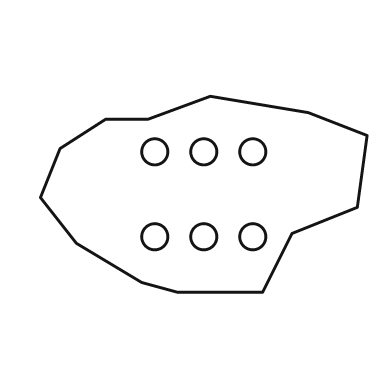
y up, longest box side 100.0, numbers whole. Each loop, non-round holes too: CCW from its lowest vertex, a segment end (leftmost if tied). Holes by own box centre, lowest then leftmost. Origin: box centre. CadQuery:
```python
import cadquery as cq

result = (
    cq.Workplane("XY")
    .moveTo(-8.0, -30.0)
    .lineTo(18.0, -30.0)
    .lineTo(27.0, -12.0)
    .lineTo(47.0, -4.0)
    .lineTo(50.0, 18.0)
    .lineTo(32.0, 25.0)
    .lineTo(2.0, 30.0)
    .lineTo(-17.0, 23.0)
    .lineTo(-30.0, 23.0)
    .lineTo(-44.0, 14.0)
    .lineTo(-50.0, -1.0)
    .lineTo(-39.0, -15.0)
    .lineTo(-19.0, -27.0)
    .close()
    .moveTo(-15.0, -13.0)
    .circle(4.0)
    .moveTo(0.0, -13.0)
    .circle(4.0)
    .moveTo(15.0, -13.0)
    .circle(4.0)
    .moveTo(-15.0, 13.0)
    .circle(4.0)
    .moveTo(0.0, 13.0)
    .circle(4.0)
    .moveTo(15.0, 13.0)
    .circle(4.0)
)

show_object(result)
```